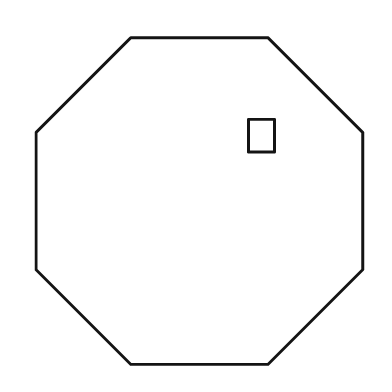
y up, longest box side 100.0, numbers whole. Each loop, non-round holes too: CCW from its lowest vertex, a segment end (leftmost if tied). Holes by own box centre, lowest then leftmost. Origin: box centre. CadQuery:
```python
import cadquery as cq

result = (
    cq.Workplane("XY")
    .moveTo(-21.0, -50.0)
    .lineTo(21.0, -50.0)
    .lineTo(50.0, -21.0)
    .lineTo(50.0, 21.0)
    .lineTo(21.0, 50.0)
    .lineTo(-21.0, 50.0)
    .lineTo(-50.0, 21.0)
    .lineTo(-50.0, -21.0)
    .close()
    .moveTo(15.0, 15.0)
    .lineTo(23.0, 15.0)
    .lineTo(23.0, 25.0)
    .lineTo(15.0, 25.0)
    .close()
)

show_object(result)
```